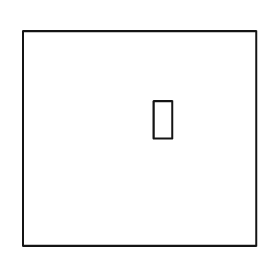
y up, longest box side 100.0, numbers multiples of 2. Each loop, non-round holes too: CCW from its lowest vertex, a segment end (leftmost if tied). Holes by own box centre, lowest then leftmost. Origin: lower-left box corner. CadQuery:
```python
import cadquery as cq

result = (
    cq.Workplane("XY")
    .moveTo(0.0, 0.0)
    .lineTo(100.0, 0.0)
    .lineTo(100.0, 92.0)
    .lineTo(0.0, 92.0)
    .close()
    .moveTo(56.0, 46.0)
    .lineTo(64.0, 46.0)
    .lineTo(64.0, 62.0)
    .lineTo(56.0, 62.0)
    .close()
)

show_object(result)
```